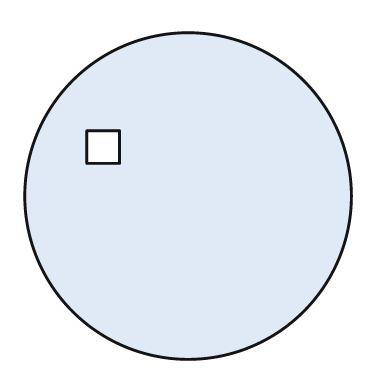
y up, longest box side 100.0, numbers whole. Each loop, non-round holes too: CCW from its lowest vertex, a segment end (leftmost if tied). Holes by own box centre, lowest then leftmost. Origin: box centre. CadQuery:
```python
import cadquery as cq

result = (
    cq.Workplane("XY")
    .moveTo(0.0, 0.0)
    .circle(50.0)
    .moveTo(-31.0, 10.0)
    .lineTo(-21.0, 10.0)
    .lineTo(-21.0, 20.0)
    .lineTo(-31.0, 20.0)
    .close()
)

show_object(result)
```